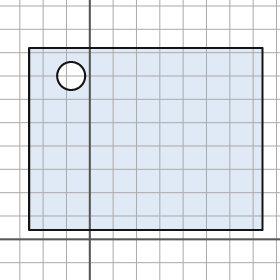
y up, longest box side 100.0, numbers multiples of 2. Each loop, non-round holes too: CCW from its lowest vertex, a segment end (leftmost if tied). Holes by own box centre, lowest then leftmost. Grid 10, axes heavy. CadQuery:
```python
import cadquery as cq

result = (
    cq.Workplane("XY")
    .moveTo(-26.0, 4.0)
    .lineTo(74.0, 4.0)
    .lineTo(74.0, 82.0)
    .lineTo(-26.0, 82.0)
    .close()
    .moveTo(-8.0, 70.0)
    .circle(6.0)
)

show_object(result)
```